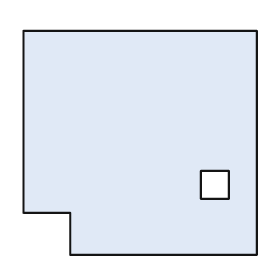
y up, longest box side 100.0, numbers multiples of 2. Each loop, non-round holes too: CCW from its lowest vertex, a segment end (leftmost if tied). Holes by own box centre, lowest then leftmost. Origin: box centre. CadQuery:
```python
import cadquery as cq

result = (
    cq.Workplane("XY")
    .moveTo(-30.0, -48.0)
    .lineTo(50.0, -48.0)
    .lineTo(50.0, 48.0)
    .lineTo(-50.0, 48.0)
    .lineTo(-50.0, -30.0)
    .lineTo(-30.0, -30.0)
    .close()
    .moveTo(26.0, -24.0)
    .lineTo(38.0, -24.0)
    .lineTo(38.0, -12.0)
    .lineTo(26.0, -12.0)
    .close()
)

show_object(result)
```